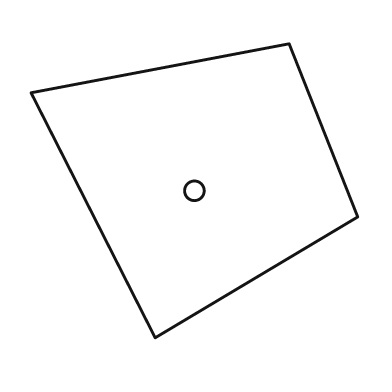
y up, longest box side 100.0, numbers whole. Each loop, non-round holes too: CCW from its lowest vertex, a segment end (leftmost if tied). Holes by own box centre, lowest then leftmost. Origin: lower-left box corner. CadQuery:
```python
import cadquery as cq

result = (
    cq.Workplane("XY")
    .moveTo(38.0, 0.0)
    .lineTo(100.0, 37.0)
    .lineTo(79.0, 90.0)
    .lineTo(0.0, 75.0)
    .close()
    .moveTo(50.0, 45.0)
    .circle(3.0)
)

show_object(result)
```